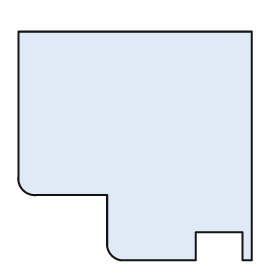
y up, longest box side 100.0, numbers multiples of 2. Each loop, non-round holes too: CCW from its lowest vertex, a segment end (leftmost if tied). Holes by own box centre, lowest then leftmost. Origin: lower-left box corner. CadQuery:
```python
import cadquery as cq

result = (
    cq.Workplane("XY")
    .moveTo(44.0, 0.0)
    .lineTo(76.0, 0.0)
    .lineTo(76.0, 12.0)
    .lineTo(96.0, 12.0)
    .lineTo(96.0, 0.0)
    .lineTo(100.0, 0.0)
    .lineTo(100.0, 98.0)
    .lineTo(0.0, 98.0)
    .lineTo(0.0, 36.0)
    .threePointArc((2.0, 30.0), (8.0, 28.0))
    .lineTo(38.0, 28.0)
    .lineTo(38.0, 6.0)
    .threePointArc((40.0, 2.0), (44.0, 0.0))
    .close()
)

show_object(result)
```